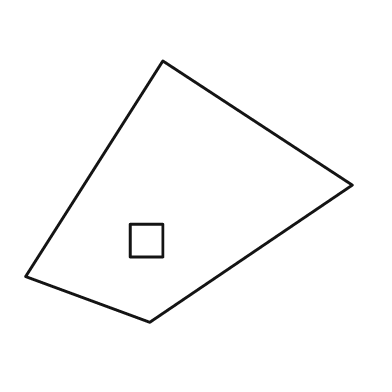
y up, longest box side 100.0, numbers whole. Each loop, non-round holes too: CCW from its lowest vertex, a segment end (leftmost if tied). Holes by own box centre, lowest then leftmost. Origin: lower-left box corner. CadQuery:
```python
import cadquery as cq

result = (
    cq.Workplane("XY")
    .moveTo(38.0, 0.0)
    .lineTo(100.0, 42.0)
    .lineTo(42.0, 80.0)
    .lineTo(0.0, 14.0)
    .close()
    .moveTo(32.0, 20.0)
    .lineTo(42.0, 20.0)
    .lineTo(42.0, 30.0)
    .lineTo(32.0, 30.0)
    .close()
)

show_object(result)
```